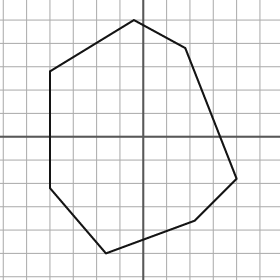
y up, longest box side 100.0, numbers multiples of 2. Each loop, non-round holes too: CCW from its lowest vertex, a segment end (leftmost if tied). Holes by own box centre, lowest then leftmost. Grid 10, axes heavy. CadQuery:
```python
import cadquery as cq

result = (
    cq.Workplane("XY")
    .moveTo(-16.0, -50.0)
    .lineTo(22.0, -36.0)
    .lineTo(40.0, -18.0)
    .lineTo(18.0, 38.0)
    .lineTo(-4.0, 50.0)
    .lineTo(-40.0, 28.0)
    .lineTo(-40.0, -22.0)
    .close()
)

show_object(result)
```